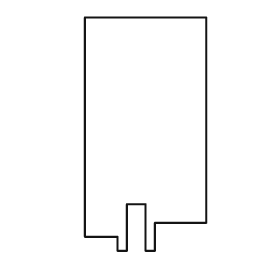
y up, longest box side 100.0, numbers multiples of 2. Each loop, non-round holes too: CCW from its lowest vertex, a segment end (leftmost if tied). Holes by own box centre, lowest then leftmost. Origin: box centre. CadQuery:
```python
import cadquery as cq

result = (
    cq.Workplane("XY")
    .moveTo(-12.0, -50.0)
    .lineTo(-8.0, -50.0)
    .lineTo(-8.0, -30.0)
    .lineTo(0.0, -30.0)
    .lineTo(0.0, -50.0)
    .lineTo(4.0, -50.0)
    .lineTo(4.0, -38.0)
    .lineTo(26.0, -38.0)
    .lineTo(26.0, 50.0)
    .lineTo(-26.0, 50.0)
    .lineTo(-26.0, -44.0)
    .lineTo(-12.0, -44.0)
    .close()
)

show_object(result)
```